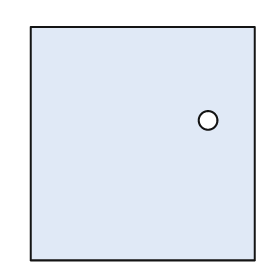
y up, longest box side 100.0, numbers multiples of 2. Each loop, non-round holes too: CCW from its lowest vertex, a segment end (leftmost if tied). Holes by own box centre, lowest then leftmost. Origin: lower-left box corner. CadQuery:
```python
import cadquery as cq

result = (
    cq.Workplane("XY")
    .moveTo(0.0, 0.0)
    .lineTo(96.0, 0.0)
    .lineTo(96.0, 100.0)
    .lineTo(0.0, 100.0)
    .close()
    .moveTo(76.0, 60.0)
    .circle(4.0)
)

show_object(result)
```